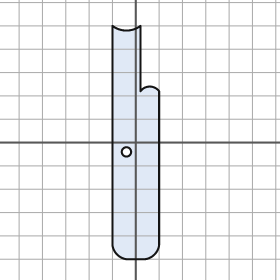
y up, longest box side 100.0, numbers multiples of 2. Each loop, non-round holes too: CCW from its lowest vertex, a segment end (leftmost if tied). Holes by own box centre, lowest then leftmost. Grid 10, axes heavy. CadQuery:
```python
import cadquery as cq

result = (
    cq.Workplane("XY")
    .moveTo(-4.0, -50.0)
    .lineTo(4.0, -50.0)
    .threePointArc((8.0, -48.0), (10.0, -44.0))
    .lineTo(10.0, 22.0)
    .threePointArc((6.0, 24.0), (2.0, 22.0))
    .lineTo(2.0, 50.0)
    .threePointArc((-4.0, 48.0), (-10.0, 50.0))
    .lineTo(-10.0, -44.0)
    .threePointArc((-8.0, -48.0), (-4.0, -50.0))
    .close()
    .moveTo(-4.0, -4.0)
    .circle(2.0)
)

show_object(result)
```